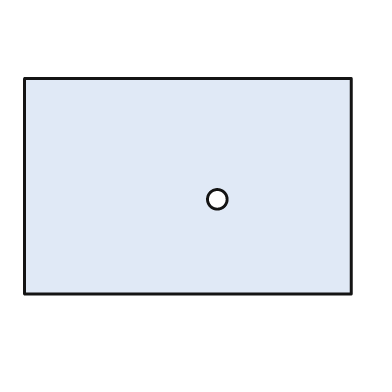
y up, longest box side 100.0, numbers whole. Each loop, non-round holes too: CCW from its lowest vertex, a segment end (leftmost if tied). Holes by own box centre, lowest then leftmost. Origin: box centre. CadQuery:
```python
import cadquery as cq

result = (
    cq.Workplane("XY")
    .moveTo(-50.0, -33.0)
    .lineTo(50.0, -33.0)
    .lineTo(50.0, 33.0)
    .lineTo(-50.0, 33.0)
    .close()
    .moveTo(9.0, -4.0)
    .circle(3.0)
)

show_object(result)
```